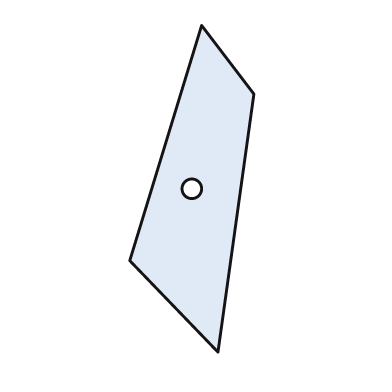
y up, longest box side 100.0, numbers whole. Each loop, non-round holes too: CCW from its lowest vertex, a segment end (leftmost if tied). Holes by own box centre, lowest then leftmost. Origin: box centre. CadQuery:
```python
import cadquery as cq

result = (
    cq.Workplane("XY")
    .moveTo(8.0, -50.0)
    .lineTo(19.0, 29.0)
    .lineTo(3.0, 50.0)
    .lineTo(-19.0, -22.0)
    .close()
    .moveTo(0.0, 0.0)
    .circle(3.0)
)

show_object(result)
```